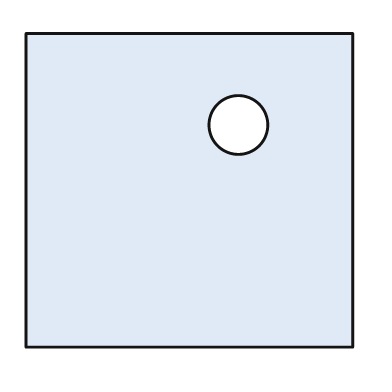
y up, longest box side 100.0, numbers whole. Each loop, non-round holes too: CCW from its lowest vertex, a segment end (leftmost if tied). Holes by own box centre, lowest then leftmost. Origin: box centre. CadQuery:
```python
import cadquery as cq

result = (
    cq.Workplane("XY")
    .moveTo(-50.0, -48.0)
    .lineTo(50.0, -48.0)
    .lineTo(50.0, 48.0)
    .lineTo(-50.0, 48.0)
    .close()
    .moveTo(15.0, 20.0)
    .circle(9.0)
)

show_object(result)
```